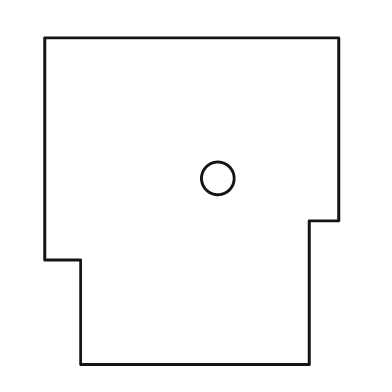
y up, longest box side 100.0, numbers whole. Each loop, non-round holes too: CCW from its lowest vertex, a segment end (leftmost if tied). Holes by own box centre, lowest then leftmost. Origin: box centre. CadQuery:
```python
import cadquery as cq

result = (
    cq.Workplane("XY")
    .moveTo(-34.0, -50.0)
    .lineTo(36.0, -50.0)
    .lineTo(36.0, -6.0)
    .lineTo(45.0, -6.0)
    .lineTo(45.0, 50.0)
    .lineTo(-45.0, 50.0)
    .lineTo(-45.0, -18.0)
    .lineTo(-34.0, -18.0)
    .close()
    .moveTo(8.0, 7.0)
    .circle(5.0)
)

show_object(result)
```